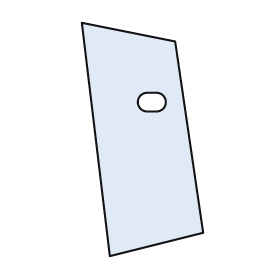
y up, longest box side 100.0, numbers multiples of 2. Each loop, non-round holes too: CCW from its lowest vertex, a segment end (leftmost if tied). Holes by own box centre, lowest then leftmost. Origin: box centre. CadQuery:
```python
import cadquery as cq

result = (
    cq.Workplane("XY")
    .moveTo(-14.0, -50.0)
    .lineTo(26.0, -40.0)
    .lineTo(14.0, 42.0)
    .lineTo(-26.0, 50.0)
    .close()
    .moveTo(2.0, 12.0)
    .lineTo(6.0, 12.0)
    .threePointArc((10.0, 16.0), (6.0, 20.0))
    .lineTo(2.0, 20.0)
    .threePointArc((-2.0, 16.0), (2.0, 12.0))
    .close()
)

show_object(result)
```